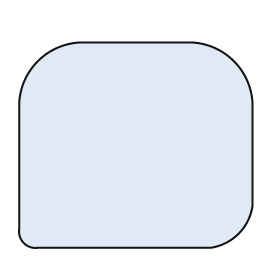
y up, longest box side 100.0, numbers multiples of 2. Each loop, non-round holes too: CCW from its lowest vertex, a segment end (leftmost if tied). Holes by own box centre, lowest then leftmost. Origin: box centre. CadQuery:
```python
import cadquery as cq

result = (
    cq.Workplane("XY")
    .moveTo(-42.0, -44.0)
    .lineTo(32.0, -44.0)
    .threePointArc((44.0, -38.0), (50.0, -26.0))
    .lineTo(50.0, 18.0)
    .threePointArc((42.0, 36.0), (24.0, 44.0))
    .lineTo(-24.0, 44.0)
    .threePointArc((-42.0, 36.0), (-50.0, 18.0))
    .lineTo(-50.0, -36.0)
    .threePointArc((-48.0, -42.0), (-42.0, -44.0))
    .close()
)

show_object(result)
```